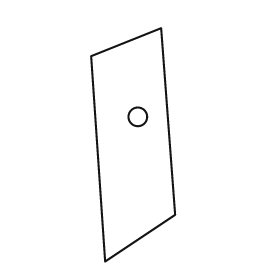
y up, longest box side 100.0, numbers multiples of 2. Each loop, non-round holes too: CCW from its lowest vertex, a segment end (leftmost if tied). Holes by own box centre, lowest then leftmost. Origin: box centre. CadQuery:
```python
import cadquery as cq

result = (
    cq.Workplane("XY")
    .moveTo(-12.0, -50.0)
    .lineTo(18.0, -30.0)
    .lineTo(12.0, 50.0)
    .lineTo(-18.0, 38.0)
    .close()
    .moveTo(2.0, 12.0)
    .circle(4.0)
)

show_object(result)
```